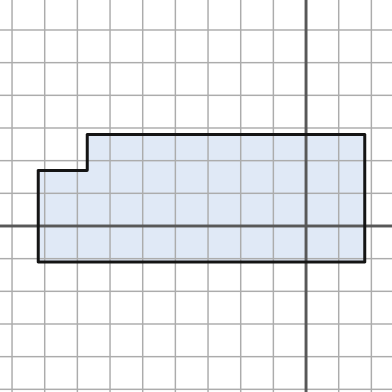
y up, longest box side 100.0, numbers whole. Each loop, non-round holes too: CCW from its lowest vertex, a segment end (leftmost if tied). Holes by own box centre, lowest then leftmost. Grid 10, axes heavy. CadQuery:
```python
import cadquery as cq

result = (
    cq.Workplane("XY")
    .moveTo(-82.0, -11.0)
    .lineTo(18.0, -11.0)
    .lineTo(18.0, 28.0)
    .lineTo(-67.0, 28.0)
    .lineTo(-67.0, 17.0)
    .lineTo(-82.0, 17.0)
    .close()
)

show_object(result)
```